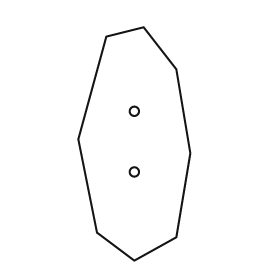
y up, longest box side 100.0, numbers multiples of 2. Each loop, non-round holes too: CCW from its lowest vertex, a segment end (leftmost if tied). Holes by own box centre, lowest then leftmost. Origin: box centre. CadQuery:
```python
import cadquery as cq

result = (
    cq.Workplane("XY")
    .moveTo(0.0, -50.0)
    .lineTo(18.0, -40.0)
    .lineTo(24.0, -4.0)
    .lineTo(18.0, 32.0)
    .lineTo(4.0, 50.0)
    .lineTo(-12.0, 46.0)
    .lineTo(-24.0, 2.0)
    .lineTo(-16.0, -38.0)
    .close()
    .moveTo(0.0, -12.0)
    .circle(2.0)
    .moveTo(0.0, 14.0)
    .circle(2.0)
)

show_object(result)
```